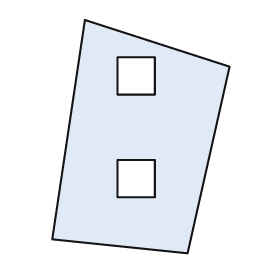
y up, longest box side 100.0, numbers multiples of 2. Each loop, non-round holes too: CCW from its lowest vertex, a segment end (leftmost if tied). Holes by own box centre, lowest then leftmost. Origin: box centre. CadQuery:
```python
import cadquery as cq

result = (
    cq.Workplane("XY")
    .moveTo(20.0, -50.0)
    .lineTo(38.0, 30.0)
    .lineTo(-24.0, 50.0)
    .lineTo(-38.0, -44.0)
    .close()
    .moveTo(-10.0, -26.0)
    .lineTo(6.0, -26.0)
    .lineTo(6.0, -10.0)
    .lineTo(-10.0, -10.0)
    .close()
    .moveTo(-10.0, 18.0)
    .lineTo(6.0, 18.0)
    .lineTo(6.0, 34.0)
    .lineTo(-10.0, 34.0)
    .close()
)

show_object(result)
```